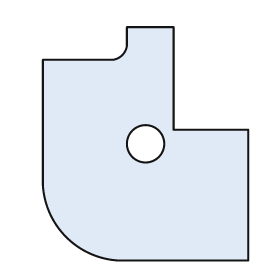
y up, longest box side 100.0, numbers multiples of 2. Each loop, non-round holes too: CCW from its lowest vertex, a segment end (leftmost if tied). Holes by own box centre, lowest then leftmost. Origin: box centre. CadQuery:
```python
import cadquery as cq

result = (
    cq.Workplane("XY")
    .moveTo(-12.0, -50.0)
    .lineTo(44.0, -50.0)
    .lineTo(44.0, 6.0)
    .lineTo(12.0, 6.0)
    .lineTo(12.0, 50.0)
    .lineTo(-8.0, 50.0)
    .lineTo(-8.0, 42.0)
    .threePointArc((-10.0, 38.0), (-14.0, 36.0))
    .lineTo(-44.0, 36.0)
    .lineTo(-44.0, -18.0)
    .threePointArc((-34.0, -40.0), (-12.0, -50.0))
    .close()
    .moveTo(0.0, 0.0)
    .circle(8.0)
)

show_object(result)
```